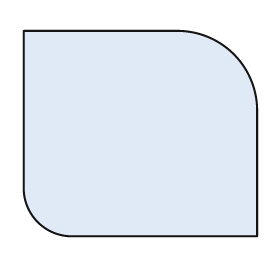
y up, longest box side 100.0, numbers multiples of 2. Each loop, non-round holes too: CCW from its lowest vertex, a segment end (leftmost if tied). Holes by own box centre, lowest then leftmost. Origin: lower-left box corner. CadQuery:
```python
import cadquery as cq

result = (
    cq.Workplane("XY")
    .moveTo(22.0, 0.0)
    .lineTo(100.0, 0.0)
    .lineTo(100.0, 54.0)
    .threePointArc((90.0, 78.0), (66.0, 88.0))
    .lineTo(0.0, 88.0)
    .lineTo(0.0, 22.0)
    .threePointArc((6.0, 6.0), (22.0, 0.0))
    .close()
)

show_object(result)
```